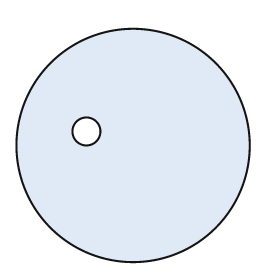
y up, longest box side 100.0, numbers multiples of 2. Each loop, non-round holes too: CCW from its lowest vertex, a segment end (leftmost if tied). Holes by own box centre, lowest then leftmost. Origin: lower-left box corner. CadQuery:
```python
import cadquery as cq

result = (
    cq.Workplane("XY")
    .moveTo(50.0, 50.0)
    .circle(50.0)
    .moveTo(30.0, 56.0)
    .circle(6.0)
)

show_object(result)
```